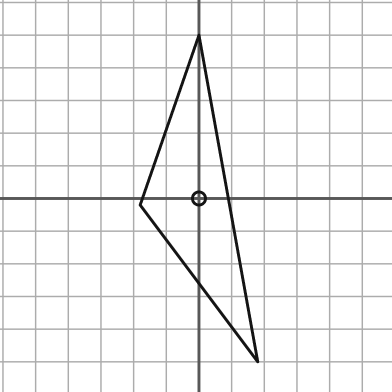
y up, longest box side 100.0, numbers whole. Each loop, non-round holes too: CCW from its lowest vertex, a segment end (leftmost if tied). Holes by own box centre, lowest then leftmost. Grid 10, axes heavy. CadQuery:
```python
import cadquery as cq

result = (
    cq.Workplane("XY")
    .moveTo(18.0, -50.0)
    .lineTo(0.0, 50.0)
    .lineTo(-18.0, -2.0)
    .close()
    .moveTo(0.0, 0.0)
    .circle(2.0)
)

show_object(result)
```